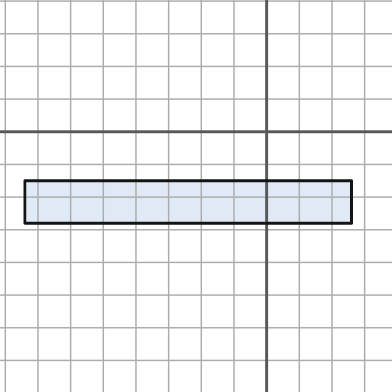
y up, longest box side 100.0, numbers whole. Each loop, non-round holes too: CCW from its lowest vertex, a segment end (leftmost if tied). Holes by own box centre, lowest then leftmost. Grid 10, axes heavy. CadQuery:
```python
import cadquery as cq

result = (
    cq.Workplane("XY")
    .moveTo(-74.0, -28.0)
    .lineTo(26.0, -28.0)
    .lineTo(26.0, -15.0)
    .lineTo(-74.0, -15.0)
    .close()
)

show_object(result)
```